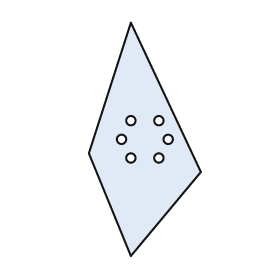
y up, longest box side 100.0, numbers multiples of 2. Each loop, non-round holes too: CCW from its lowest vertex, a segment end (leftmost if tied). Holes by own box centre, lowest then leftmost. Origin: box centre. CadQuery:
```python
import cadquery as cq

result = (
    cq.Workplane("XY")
    .moveTo(-6.0, -50.0)
    .lineTo(24.0, -14.0)
    .lineTo(-6.0, 50.0)
    .lineTo(-24.0, -6.0)
    .close()
    .moveTo(-6.0, -8.0)
    .circle(2.0)
    .moveTo(6.0, -8.0)
    .circle(2.0)
    .moveTo(-10.0, 0.0)
    .circle(2.0)
    .moveTo(10.0, 0.0)
    .circle(2.0)
    .moveTo(-6.0, 8.0)
    .circle(2.0)
    .moveTo(6.0, 8.0)
    .circle(2.0)
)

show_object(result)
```